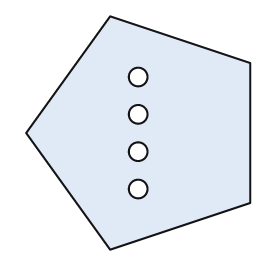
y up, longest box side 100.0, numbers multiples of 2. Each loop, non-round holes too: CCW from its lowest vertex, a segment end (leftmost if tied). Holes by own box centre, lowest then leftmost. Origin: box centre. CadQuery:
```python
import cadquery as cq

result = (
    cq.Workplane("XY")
    .moveTo(-12.0, -50.0)
    .lineTo(48.0, -30.0)
    .lineTo(48.0, 30.0)
    .lineTo(-12.0, 50.0)
    .lineTo(-48.0, 0.0)
    .close()
    .moveTo(0.0, -24.0)
    .circle(4.0)
    .moveTo(0.0, -8.0)
    .circle(4.0)
    .moveTo(0.0, 8.0)
    .circle(4.0)
    .moveTo(0.0, 24.0)
    .circle(4.0)
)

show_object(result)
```